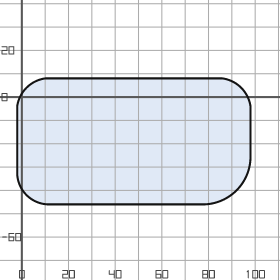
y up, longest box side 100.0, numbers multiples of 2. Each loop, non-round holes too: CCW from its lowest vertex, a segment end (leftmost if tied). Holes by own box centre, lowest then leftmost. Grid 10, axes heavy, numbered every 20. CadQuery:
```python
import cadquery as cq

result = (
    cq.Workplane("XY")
    .moveTo(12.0, -46.0)
    .lineTo(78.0, -46.0)
    .threePointArc((92.0, -40.0), (98.0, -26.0))
    .lineTo(98.0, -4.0)
    .threePointArc((94.0, 4.0), (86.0, 8.0))
    .lineTo(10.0, 8.0)
    .threePointArc((2.0, 4.0), (-2.0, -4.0))
    .lineTo(-2.0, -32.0)
    .threePointArc((2.0, -42.0), (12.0, -46.0))
    .close()
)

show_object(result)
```